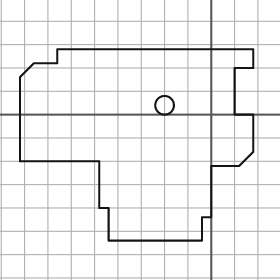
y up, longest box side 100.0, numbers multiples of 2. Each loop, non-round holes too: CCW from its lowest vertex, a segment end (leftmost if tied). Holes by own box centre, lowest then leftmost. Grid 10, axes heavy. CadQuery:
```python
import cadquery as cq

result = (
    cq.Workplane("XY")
    .moveTo(-44.0, -54.0)
    .lineTo(-4.0, -54.0)
    .lineTo(-4.0, -44.0)
    .lineTo(0.0, -44.0)
    .lineTo(0.0, -22.0)
    .lineTo(12.0, -22.0)
    .lineTo(18.0, -16.0)
    .lineTo(18.0, 0.0)
    .lineTo(10.0, 0.0)
    .lineTo(10.0, 20.0)
    .lineTo(18.0, 20.0)
    .lineTo(18.0, 28.0)
    .lineTo(-66.0, 28.0)
    .lineTo(-66.0, 22.0)
    .lineTo(-76.0, 22.0)
    .lineTo(-82.0, 16.0)
    .lineTo(-82.0, -20.0)
    .lineTo(-48.0, -20.0)
    .lineTo(-48.0, -40.0)
    .lineTo(-44.0, -40.0)
    .close()
    .moveTo(-20.0, 4.0)
    .circle(4.0)
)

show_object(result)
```